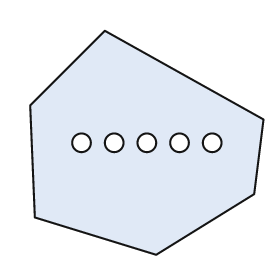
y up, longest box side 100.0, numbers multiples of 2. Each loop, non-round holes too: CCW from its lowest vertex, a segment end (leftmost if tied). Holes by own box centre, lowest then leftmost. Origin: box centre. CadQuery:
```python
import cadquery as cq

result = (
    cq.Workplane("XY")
    .moveTo(4.0, -48.0)
    .lineTo(46.0, -22.0)
    .lineTo(50.0, 10.0)
    .lineTo(-18.0, 48.0)
    .lineTo(-50.0, 16.0)
    .lineTo(-48.0, -32.0)
    .close()
    .moveTo(-28.0, 0.0)
    .circle(4.0)
    .moveTo(-14.0, 0.0)
    .circle(4.0)
    .moveTo(0.0, 0.0)
    .circle(4.0)
    .moveTo(14.0, 0.0)
    .circle(4.0)
    .moveTo(28.0, 0.0)
    .circle(4.0)
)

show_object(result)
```